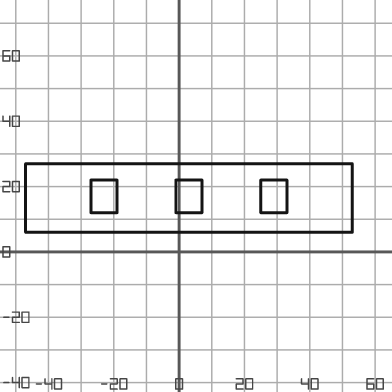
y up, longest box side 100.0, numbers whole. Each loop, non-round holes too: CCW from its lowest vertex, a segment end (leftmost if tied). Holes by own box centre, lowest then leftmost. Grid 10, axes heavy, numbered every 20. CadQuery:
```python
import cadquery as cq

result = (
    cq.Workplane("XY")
    .moveTo(-47.0, 6.0)
    .lineTo(53.0, 6.0)
    .lineTo(53.0, 27.0)
    .lineTo(-47.0, 27.0)
    .close()
    .moveTo(-27.0, 12.0)
    .lineTo(-19.0, 12.0)
    .lineTo(-19.0, 22.0)
    .lineTo(-27.0, 22.0)
    .close()
    .moveTo(-1.0, 12.0)
    .lineTo(7.0, 12.0)
    .lineTo(7.0, 22.0)
    .lineTo(-1.0, 22.0)
    .close()
    .moveTo(25.0, 12.0)
    .lineTo(33.0, 12.0)
    .lineTo(33.0, 22.0)
    .lineTo(25.0, 22.0)
    .close()
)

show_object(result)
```